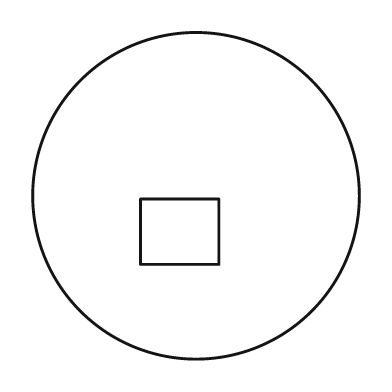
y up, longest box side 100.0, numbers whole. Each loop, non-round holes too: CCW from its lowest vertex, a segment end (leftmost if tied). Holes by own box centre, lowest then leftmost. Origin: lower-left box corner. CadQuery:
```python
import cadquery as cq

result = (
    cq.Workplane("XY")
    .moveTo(50.0, 50.0)
    .circle(50.0)
    .moveTo(33.0, 29.0)
    .lineTo(57.0, 29.0)
    .lineTo(57.0, 49.0)
    .lineTo(33.0, 49.0)
    .close()
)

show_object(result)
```